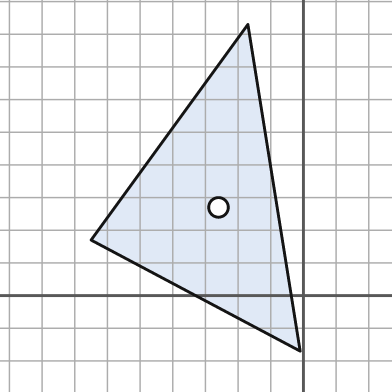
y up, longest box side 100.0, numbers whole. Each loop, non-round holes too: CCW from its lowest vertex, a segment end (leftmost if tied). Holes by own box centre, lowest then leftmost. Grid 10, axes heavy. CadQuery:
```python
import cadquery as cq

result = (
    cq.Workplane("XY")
    .moveTo(-1.0, -17.0)
    .lineTo(-17.0, 83.0)
    .lineTo(-65.0, 17.0)
    .close()
    .moveTo(-26.0, 27.0)
    .circle(3.0)
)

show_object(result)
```